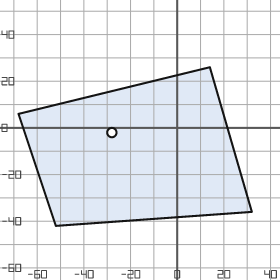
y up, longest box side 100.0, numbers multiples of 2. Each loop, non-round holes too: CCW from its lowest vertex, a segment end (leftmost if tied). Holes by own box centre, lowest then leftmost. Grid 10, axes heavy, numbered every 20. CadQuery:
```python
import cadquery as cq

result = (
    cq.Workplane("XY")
    .moveTo(-52.0, -42.0)
    .lineTo(32.0, -36.0)
    .lineTo(14.0, 26.0)
    .lineTo(-68.0, 6.0)
    .close()
    .moveTo(-28.0, -2.0)
    .circle(2.0)
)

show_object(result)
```